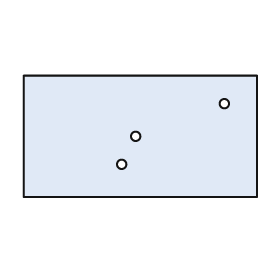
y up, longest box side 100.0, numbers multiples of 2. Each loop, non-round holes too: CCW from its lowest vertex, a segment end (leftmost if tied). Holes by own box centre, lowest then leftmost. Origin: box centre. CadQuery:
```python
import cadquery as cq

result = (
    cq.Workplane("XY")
    .moveTo(-50.0, -26.0)
    .lineTo(50.0, -26.0)
    .lineTo(50.0, 26.0)
    .lineTo(-50.0, 26.0)
    .close()
    .moveTo(-8.0, -12.0)
    .circle(2.0)
    .moveTo(-2.0, 0.0)
    .circle(2.0)
    .moveTo(36.0, 14.0)
    .circle(2.0)
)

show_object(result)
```